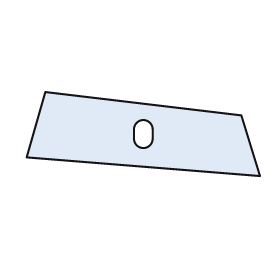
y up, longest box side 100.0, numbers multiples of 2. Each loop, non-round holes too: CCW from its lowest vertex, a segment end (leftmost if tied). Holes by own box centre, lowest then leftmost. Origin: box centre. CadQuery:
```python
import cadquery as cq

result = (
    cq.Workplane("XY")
    .moveTo(50.0, -18.0)
    .lineTo(42.0, 8.0)
    .lineTo(-42.0, 18.0)
    .lineTo(-50.0, -10.0)
    .close()
    .moveTo(-4.0, -2.0)
    .threePointArc((0.0, -6.0), (4.0, -2.0))
    .lineTo(4.0, 2.0)
    .threePointArc((0.0, 6.0), (-4.0, 2.0))
    .close()
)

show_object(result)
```